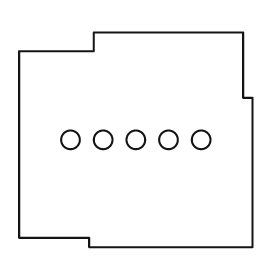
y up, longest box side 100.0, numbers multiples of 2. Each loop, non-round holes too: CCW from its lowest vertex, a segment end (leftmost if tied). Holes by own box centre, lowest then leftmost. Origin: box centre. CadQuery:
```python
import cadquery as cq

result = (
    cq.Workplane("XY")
    .moveTo(-20.0, -46.0)
    .lineTo(50.0, -46.0)
    .lineTo(50.0, 18.0)
    .lineTo(46.0, 18.0)
    .lineTo(46.0, 46.0)
    .lineTo(-18.0, 46.0)
    .lineTo(-18.0, 38.0)
    .lineTo(-50.0, 38.0)
    .lineTo(-50.0, -42.0)
    .lineTo(-20.0, -42.0)
    .close()
    .moveTo(-28.0, 0.0)
    .circle(4.0)
    .moveTo(-14.0, 0.0)
    .circle(4.0)
    .moveTo(0.0, 0.0)
    .circle(4.0)
    .moveTo(14.0, 0.0)
    .circle(4.0)
    .moveTo(28.0, 0.0)
    .circle(4.0)
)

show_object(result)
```